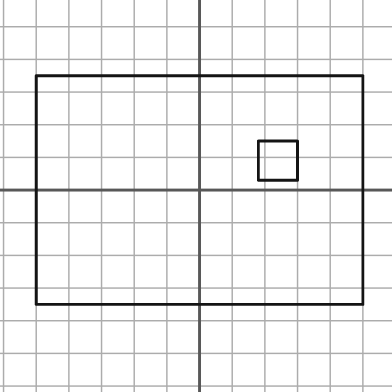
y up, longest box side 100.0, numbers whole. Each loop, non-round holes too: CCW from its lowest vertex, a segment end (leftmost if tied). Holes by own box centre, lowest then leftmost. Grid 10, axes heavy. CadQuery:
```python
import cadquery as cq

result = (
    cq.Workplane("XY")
    .moveTo(-50.0, -35.0)
    .lineTo(50.0, -35.0)
    .lineTo(50.0, 35.0)
    .lineTo(-50.0, 35.0)
    .close()
    .moveTo(18.0, 3.0)
    .lineTo(30.0, 3.0)
    .lineTo(30.0, 15.0)
    .lineTo(18.0, 15.0)
    .close()
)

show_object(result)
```